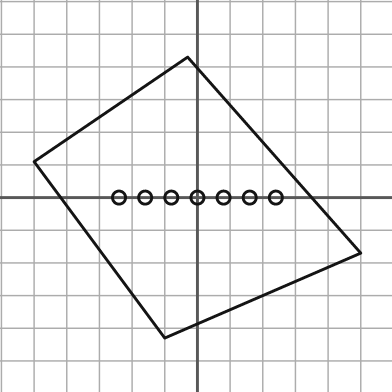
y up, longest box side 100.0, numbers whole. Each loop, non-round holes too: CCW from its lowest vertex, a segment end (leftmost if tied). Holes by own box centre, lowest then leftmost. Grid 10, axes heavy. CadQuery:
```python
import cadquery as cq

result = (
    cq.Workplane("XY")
    .moveTo(-10.0, -43.0)
    .lineTo(50.0, -17.0)
    .lineTo(-3.0, 43.0)
    .lineTo(-50.0, 11.0)
    .close()
    .moveTo(-24.0, 0.0)
    .circle(2.0)
    .moveTo(-16.0, 0.0)
    .circle(2.0)
    .moveTo(-8.0, 0.0)
    .circle(2.0)
    .moveTo(0.0, 0.0)
    .circle(2.0)
    .moveTo(8.0, 0.0)
    .circle(2.0)
    .moveTo(16.0, 0.0)
    .circle(2.0)
    .moveTo(24.0, 0.0)
    .circle(2.0)
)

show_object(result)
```